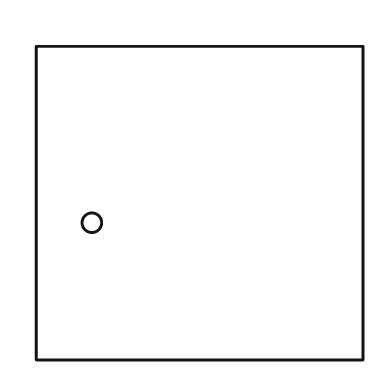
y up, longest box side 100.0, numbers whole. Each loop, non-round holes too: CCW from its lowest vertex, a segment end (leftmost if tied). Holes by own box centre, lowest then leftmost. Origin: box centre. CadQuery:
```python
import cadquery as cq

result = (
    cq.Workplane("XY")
    .moveTo(-50.0, -48.0)
    .lineTo(50.0, -48.0)
    .lineTo(50.0, 48.0)
    .lineTo(-50.0, 48.0)
    .close()
    .moveTo(-33.0, -6.0)
    .circle(3.0)
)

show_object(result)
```